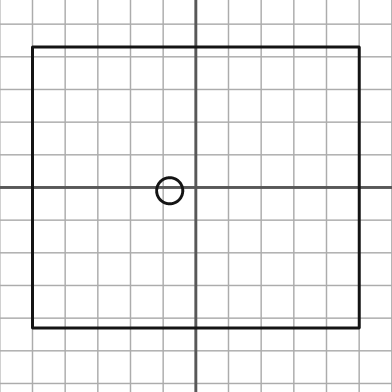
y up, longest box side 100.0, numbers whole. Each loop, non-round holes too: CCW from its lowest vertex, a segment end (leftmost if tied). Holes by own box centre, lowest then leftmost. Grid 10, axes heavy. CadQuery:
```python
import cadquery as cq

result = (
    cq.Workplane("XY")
    .moveTo(-50.0, -43.0)
    .lineTo(50.0, -43.0)
    .lineTo(50.0, 43.0)
    .lineTo(-50.0, 43.0)
    .close()
    .moveTo(-8.0, -1.0)
    .circle(4.0)
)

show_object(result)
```